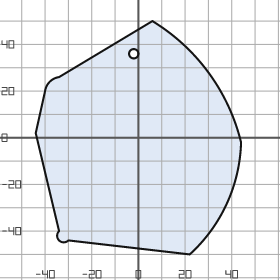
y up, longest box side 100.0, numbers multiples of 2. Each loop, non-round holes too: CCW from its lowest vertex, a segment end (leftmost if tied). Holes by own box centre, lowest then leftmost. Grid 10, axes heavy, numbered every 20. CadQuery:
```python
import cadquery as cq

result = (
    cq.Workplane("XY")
    .moveTo(22.0, -50.0)
    .threePointArc((38.0, -28.0), (44.0, -2.0))
    .threePointArc((30.0, 28.0), (6.0, 50.0))
    .lineTo(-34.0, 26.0)
    .threePointArc((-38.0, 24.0), (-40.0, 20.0))
    .lineTo(-44.0, 2.0)
    .lineTo(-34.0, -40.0)
    .threePointArc((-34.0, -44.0), (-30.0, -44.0))
    .close()
    .moveTo(-2.0, 36.0)
    .circle(2.0)
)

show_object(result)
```